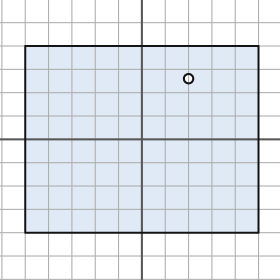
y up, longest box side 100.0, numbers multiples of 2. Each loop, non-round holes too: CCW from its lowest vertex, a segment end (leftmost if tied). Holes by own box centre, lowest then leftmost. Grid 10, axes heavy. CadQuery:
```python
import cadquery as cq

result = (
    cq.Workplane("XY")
    .moveTo(-50.0, -40.0)
    .lineTo(50.0, -40.0)
    .lineTo(50.0, 40.0)
    .lineTo(-50.0, 40.0)
    .close()
    .moveTo(20.0, 26.0)
    .circle(2.0)
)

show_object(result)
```